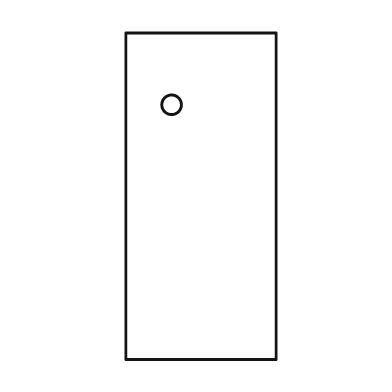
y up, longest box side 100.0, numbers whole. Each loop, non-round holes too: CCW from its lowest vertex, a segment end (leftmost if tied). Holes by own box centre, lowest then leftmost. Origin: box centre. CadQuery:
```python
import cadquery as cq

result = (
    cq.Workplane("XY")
    .moveTo(-23.0, -50.0)
    .lineTo(23.0, -50.0)
    .lineTo(23.0, 50.0)
    .lineTo(-23.0, 50.0)
    .close()
    .moveTo(-9.0, 28.0)
    .circle(3.0)
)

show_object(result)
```